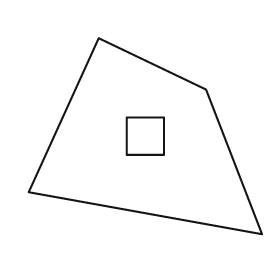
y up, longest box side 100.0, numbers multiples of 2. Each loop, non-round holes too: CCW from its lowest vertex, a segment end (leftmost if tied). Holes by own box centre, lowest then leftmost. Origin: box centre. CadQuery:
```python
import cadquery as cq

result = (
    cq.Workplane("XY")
    .moveTo(50.0, -42.0)
    .lineTo(26.0, 20.0)
    .lineTo(-20.0, 42.0)
    .lineTo(-50.0, -24.0)
    .close()
    .moveTo(-8.0, -8.0)
    .lineTo(8.0, -8.0)
    .lineTo(8.0, 8.0)
    .lineTo(-8.0, 8.0)
    .close()
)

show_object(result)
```